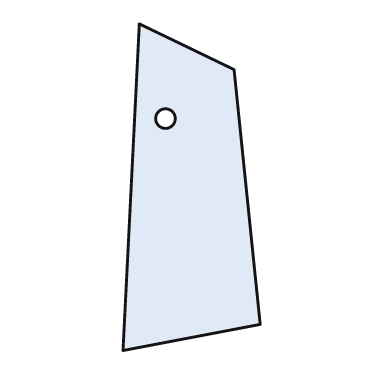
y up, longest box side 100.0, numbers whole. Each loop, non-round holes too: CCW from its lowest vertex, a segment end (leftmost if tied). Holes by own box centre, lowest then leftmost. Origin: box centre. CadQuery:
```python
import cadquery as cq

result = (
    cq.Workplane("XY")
    .moveTo(-21.0, -50.0)
    .lineTo(21.0, -42.0)
    .lineTo(13.0, 36.0)
    .lineTo(-16.0, 50.0)
    .close()
    .moveTo(-8.0, 21.0)
    .circle(3.0)
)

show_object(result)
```